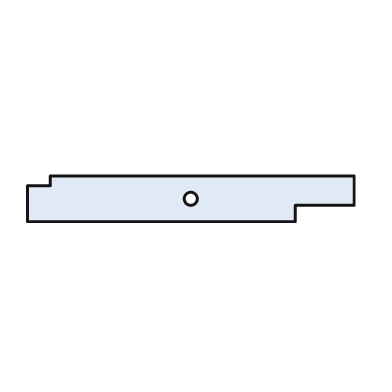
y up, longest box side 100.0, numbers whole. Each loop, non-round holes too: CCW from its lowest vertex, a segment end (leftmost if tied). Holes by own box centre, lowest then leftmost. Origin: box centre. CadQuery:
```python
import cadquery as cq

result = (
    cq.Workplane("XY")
    .moveTo(-50.0, -7.0)
    .lineTo(32.0, -7.0)
    .lineTo(32.0, -2.0)
    .lineTo(50.0, -2.0)
    .lineTo(50.0, 7.0)
    .lineTo(-43.0, 7.0)
    .lineTo(-43.0, 4.0)
    .lineTo(-50.0, 4.0)
    .close()
    .moveTo(0.0, 0.0)
    .circle(2.0)
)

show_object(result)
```